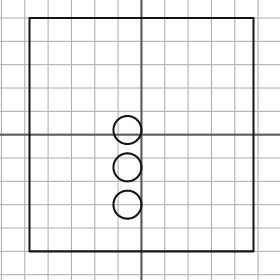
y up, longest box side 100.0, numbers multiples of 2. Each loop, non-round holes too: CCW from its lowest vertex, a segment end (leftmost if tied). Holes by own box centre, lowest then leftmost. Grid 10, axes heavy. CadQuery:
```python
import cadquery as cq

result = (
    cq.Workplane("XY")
    .moveTo(-48.0, -50.0)
    .lineTo(48.0, -50.0)
    .lineTo(48.0, 50.0)
    .lineTo(-48.0, 50.0)
    .close()
    .moveTo(-6.0, -30.0)
    .circle(6.0)
    .moveTo(-6.0, -14.0)
    .circle(6.0)
    .moveTo(-6.0, 2.0)
    .circle(6.0)
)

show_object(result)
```